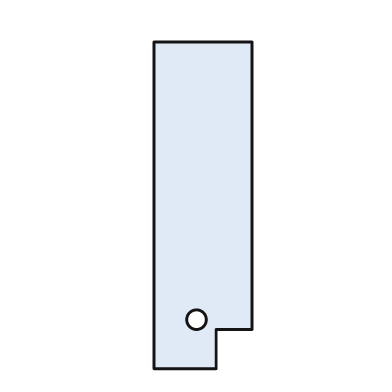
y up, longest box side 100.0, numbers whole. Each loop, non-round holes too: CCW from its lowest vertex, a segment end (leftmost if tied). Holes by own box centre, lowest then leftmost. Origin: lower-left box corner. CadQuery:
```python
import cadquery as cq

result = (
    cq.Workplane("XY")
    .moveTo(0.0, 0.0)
    .lineTo(19.0, 0.0)
    .lineTo(19.0, 12.0)
    .lineTo(30.0, 12.0)
    .lineTo(30.0, 100.0)
    .lineTo(0.0, 100.0)
    .close()
    .moveTo(13.0, 15.0)
    .circle(3.0)
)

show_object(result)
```